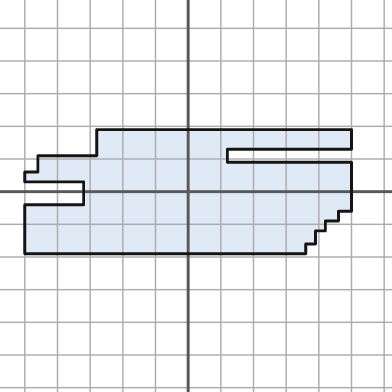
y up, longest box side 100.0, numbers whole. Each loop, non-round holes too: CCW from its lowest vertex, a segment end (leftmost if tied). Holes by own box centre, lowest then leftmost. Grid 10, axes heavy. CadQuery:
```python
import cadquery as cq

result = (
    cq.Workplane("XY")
    .moveTo(-50.0, -19.0)
    .lineTo(36.0, -19.0)
    .lineTo(36.0, -16.0)
    .lineTo(39.0, -16.0)
    .lineTo(39.0, -12.0)
    .lineTo(42.0, -12.0)
    .lineTo(42.0, -9.0)
    .lineTo(46.0, -9.0)
    .lineTo(46.0, -6.0)
    .lineTo(50.0, -6.0)
    .lineTo(50.0, 9.0)
    .lineTo(12.0, 9.0)
    .lineTo(12.0, 13.0)
    .lineTo(50.0, 13.0)
    .lineTo(50.0, 19.0)
    .lineTo(-28.0, 19.0)
    .lineTo(-28.0, 11.0)
    .lineTo(-46.0, 11.0)
    .lineTo(-46.0, 6.0)
    .lineTo(-50.0, 6.0)
    .lineTo(-50.0, 3.0)
    .lineTo(-32.0, 3.0)
    .lineTo(-32.0, -4.0)
    .lineTo(-50.0, -4.0)
    .close()
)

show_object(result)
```